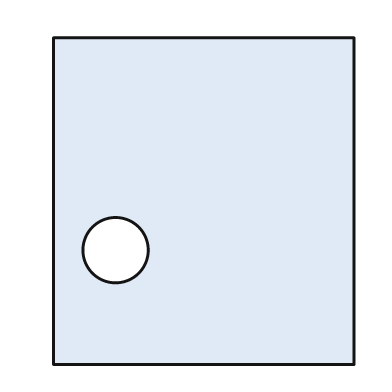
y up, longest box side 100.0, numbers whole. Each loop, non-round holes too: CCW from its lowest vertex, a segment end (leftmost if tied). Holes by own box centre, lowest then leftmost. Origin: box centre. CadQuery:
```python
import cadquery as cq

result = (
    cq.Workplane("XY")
    .moveTo(-46.0, -50.0)
    .lineTo(46.0, -50.0)
    .lineTo(46.0, 50.0)
    .lineTo(-46.0, 50.0)
    .close()
    .moveTo(-27.0, -15.0)
    .circle(10.0)
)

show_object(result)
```